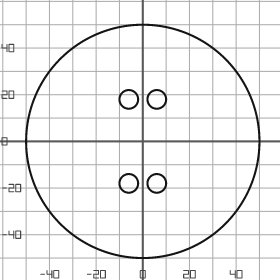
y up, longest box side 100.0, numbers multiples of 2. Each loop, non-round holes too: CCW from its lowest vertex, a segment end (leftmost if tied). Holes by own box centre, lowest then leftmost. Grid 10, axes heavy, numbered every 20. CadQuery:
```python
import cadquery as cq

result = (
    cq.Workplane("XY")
    .moveTo(0.0, 0.0)
    .circle(50.0)
    .moveTo(-6.0, -18.0)
    .circle(4.0)
    .moveTo(6.0, -18.0)
    .circle(4.0)
    .moveTo(-6.0, 18.0)
    .circle(4.0)
    .moveTo(6.0, 18.0)
    .circle(4.0)
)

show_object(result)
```